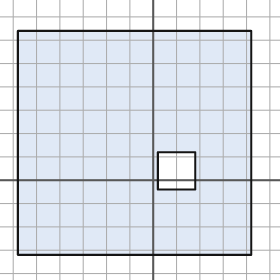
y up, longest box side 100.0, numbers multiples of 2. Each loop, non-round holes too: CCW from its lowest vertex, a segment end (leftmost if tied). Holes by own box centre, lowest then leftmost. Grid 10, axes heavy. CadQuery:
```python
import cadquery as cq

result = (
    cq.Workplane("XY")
    .moveTo(-58.0, -32.0)
    .lineTo(42.0, -32.0)
    .lineTo(42.0, 64.0)
    .lineTo(-58.0, 64.0)
    .close()
    .moveTo(2.0, -4.0)
    .lineTo(18.0, -4.0)
    .lineTo(18.0, 12.0)
    .lineTo(2.0, 12.0)
    .close()
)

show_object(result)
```